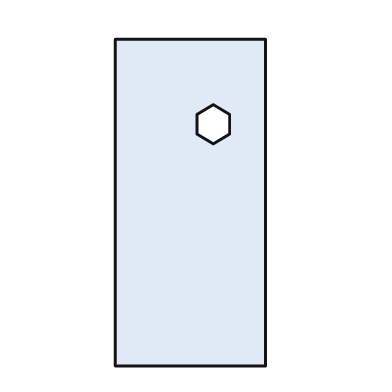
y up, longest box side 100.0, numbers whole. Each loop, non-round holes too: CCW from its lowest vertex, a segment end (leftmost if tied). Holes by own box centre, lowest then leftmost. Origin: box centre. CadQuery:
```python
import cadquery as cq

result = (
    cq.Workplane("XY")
    .moveTo(-23.0, -50.0)
    .lineTo(23.0, -50.0)
    .lineTo(23.0, 50.0)
    .lineTo(-23.0, 50.0)
    .close()
    .moveTo(7.0, 18.0)
    .lineTo(12.0, 21.0)
    .lineTo(12.0, 27.0)
    .lineTo(7.0, 30.0)
    .lineTo(2.0, 27.0)
    .lineTo(2.0, 21.0)
    .close()
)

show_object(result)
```